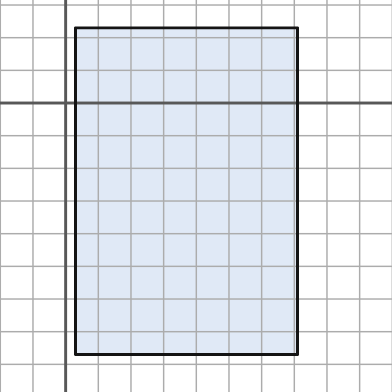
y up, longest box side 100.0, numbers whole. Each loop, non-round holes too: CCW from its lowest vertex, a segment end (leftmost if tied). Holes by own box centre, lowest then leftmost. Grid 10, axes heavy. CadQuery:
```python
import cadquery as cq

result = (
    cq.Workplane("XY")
    .moveTo(3.0, -77.0)
    .lineTo(71.0, -77.0)
    .lineTo(71.0, 23.0)
    .lineTo(3.0, 23.0)
    .close()
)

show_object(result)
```